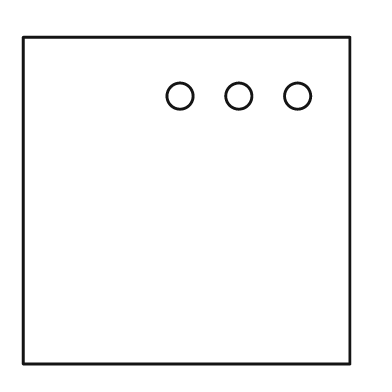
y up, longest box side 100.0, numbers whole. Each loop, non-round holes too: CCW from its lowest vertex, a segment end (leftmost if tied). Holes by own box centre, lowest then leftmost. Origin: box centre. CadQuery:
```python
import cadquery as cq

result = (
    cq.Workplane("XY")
    .moveTo(-50.0, -50.0)
    .lineTo(50.0, -50.0)
    .lineTo(50.0, 50.0)
    .lineTo(-50.0, 50.0)
    .close()
    .moveTo(-2.0, 32.0)
    .circle(4.0)
    .moveTo(16.0, 32.0)
    .circle(4.0)
    .moveTo(34.0, 32.0)
    .circle(4.0)
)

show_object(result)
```